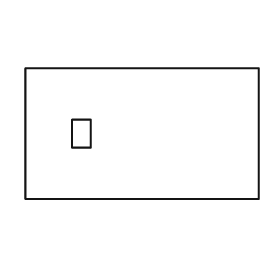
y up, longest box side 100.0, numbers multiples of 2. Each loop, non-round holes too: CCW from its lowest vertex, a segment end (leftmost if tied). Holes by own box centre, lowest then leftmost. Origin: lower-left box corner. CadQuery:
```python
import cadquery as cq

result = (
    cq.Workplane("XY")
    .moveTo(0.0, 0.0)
    .lineTo(100.0, 0.0)
    .lineTo(100.0, 56.0)
    .lineTo(0.0, 56.0)
    .close()
    .moveTo(20.0, 22.0)
    .lineTo(28.0, 22.0)
    .lineTo(28.0, 34.0)
    .lineTo(20.0, 34.0)
    .close()
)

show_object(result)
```